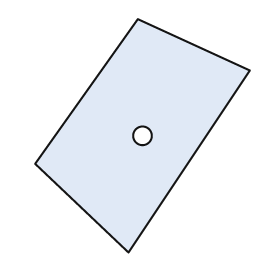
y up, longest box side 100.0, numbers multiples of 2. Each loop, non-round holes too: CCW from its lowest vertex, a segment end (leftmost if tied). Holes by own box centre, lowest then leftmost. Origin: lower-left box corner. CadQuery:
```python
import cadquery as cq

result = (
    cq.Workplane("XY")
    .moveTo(40.0, 0.0)
    .lineTo(92.0, 78.0)
    .lineTo(44.0, 100.0)
    .lineTo(0.0, 38.0)
    .close()
    .moveTo(46.0, 50.0)
    .circle(4.0)
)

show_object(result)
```